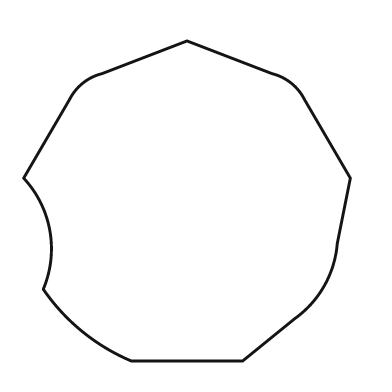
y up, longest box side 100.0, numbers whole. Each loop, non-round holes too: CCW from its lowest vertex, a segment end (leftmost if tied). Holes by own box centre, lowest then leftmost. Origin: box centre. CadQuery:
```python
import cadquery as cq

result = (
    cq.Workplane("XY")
    .moveTo(-17.0, -49.0)
    .lineTo(17.0, -49.0)
    .lineTo(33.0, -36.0)
    .threePointArc((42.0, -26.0), (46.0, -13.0))
    .lineTo(50.0, 7.0)
    .lineTo(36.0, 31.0)
    .threePointArc((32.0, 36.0), (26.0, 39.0))
    .lineTo(0.0, 49.0)
    .lineTo(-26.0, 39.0)
    .threePointArc((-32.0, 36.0), (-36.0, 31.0))
    .lineTo(-50.0, 7.0)
    .threePointArc((-42.0, -9.0), (-44.0, -27.0))
    .threePointArc((-32.0, -40.0), (-17.0, -49.0))
    .close()
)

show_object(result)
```